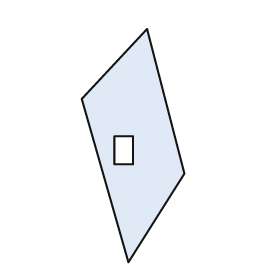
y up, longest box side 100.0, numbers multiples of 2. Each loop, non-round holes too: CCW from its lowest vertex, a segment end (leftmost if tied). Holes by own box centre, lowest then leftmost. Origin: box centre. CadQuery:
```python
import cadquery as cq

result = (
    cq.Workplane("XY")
    .moveTo(-2.0, -50.0)
    .lineTo(22.0, -12.0)
    .lineTo(6.0, 50.0)
    .lineTo(-22.0, 20.0)
    .close()
    .moveTo(-8.0, -8.0)
    .lineTo(0.0, -8.0)
    .lineTo(0.0, 4.0)
    .lineTo(-8.0, 4.0)
    .close()
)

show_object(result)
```